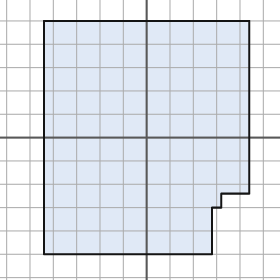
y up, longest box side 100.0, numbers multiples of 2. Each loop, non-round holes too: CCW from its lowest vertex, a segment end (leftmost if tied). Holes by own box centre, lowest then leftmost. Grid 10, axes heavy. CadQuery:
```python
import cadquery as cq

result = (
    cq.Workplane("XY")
    .moveTo(-44.0, -50.0)
    .lineTo(28.0, -50.0)
    .lineTo(28.0, -30.0)
    .lineTo(32.0, -30.0)
    .lineTo(32.0, -24.0)
    .lineTo(44.0, -24.0)
    .lineTo(44.0, 50.0)
    .lineTo(-44.0, 50.0)
    .close()
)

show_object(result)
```